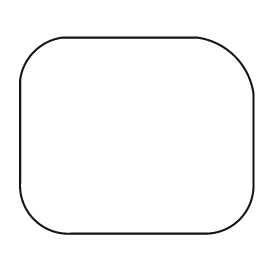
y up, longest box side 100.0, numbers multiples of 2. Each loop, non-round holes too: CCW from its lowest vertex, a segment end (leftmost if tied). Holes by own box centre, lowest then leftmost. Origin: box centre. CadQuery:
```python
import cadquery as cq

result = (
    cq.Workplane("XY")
    .moveTo(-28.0, -42.0)
    .lineTo(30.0, -42.0)
    .threePointArc((44.0, -36.0), (50.0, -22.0))
    .lineTo(50.0, 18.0)
    .threePointArc((42.0, 34.0), (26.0, 42.0))
    .lineTo(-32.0, 42.0)
    .threePointArc((-44.0, 36.0), (-50.0, 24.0))
    .lineTo(-50.0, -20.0)
    .threePointArc((-44.0, -36.0), (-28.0, -42.0))
    .close()
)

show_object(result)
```